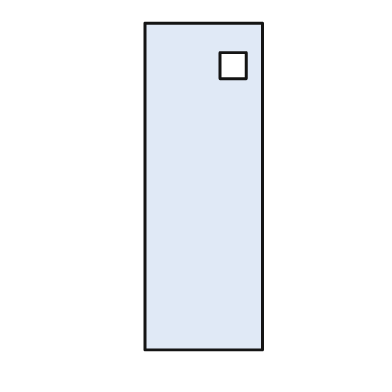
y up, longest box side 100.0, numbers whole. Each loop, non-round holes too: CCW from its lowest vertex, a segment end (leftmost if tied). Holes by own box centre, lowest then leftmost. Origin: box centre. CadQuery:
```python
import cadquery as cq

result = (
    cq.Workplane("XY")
    .moveTo(-18.0, -50.0)
    .lineTo(18.0, -50.0)
    .lineTo(18.0, 50.0)
    .lineTo(-18.0, 50.0)
    .close()
    .moveTo(5.0, 33.0)
    .lineTo(13.0, 33.0)
    .lineTo(13.0, 41.0)
    .lineTo(5.0, 41.0)
    .close()
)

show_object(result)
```